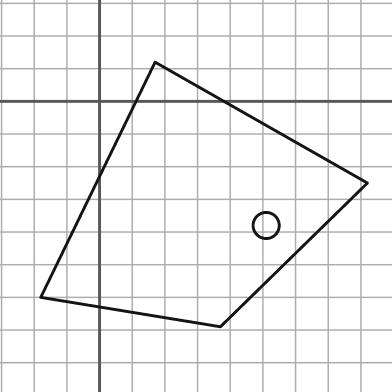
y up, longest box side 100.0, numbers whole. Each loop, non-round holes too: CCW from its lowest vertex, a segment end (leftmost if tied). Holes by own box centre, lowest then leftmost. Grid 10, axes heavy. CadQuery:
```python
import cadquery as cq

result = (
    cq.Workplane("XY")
    .moveTo(37.0, -69.0)
    .lineTo(82.0, -25.0)
    .lineTo(17.0, 12.0)
    .lineTo(-18.0, -60.0)
    .close()
    .moveTo(51.0, -38.0)
    .circle(4.0)
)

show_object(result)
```